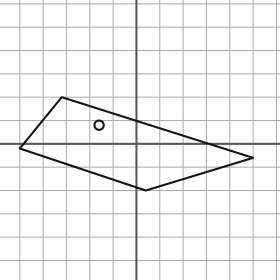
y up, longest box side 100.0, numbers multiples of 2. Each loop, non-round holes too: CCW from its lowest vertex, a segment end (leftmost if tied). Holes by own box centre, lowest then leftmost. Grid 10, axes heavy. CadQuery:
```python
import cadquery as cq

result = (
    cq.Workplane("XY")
    .moveTo(4.0, -20.0)
    .lineTo(50.0, -6.0)
    .lineTo(-32.0, 20.0)
    .lineTo(-50.0, -2.0)
    .close()
    .moveTo(-16.0, 8.0)
    .circle(2.0)
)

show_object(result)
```